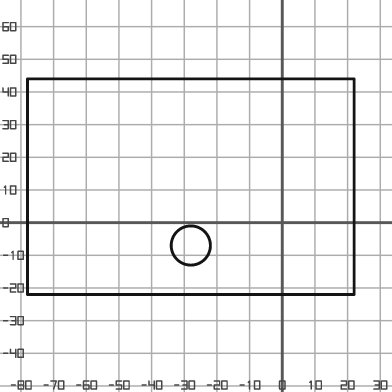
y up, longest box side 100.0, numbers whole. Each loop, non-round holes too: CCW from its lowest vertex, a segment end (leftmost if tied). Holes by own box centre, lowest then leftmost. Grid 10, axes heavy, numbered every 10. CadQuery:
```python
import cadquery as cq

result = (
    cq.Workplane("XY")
    .moveTo(-78.0, -22.0)
    .lineTo(22.0, -22.0)
    .lineTo(22.0, 44.0)
    .lineTo(-78.0, 44.0)
    .close()
    .moveTo(-28.0, -7.0)
    .circle(6.0)
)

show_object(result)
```